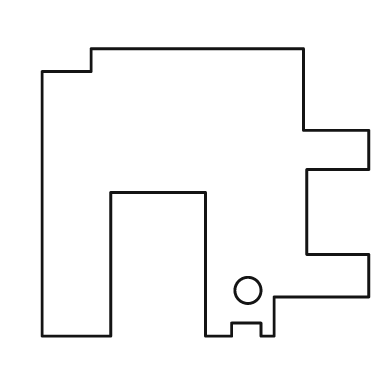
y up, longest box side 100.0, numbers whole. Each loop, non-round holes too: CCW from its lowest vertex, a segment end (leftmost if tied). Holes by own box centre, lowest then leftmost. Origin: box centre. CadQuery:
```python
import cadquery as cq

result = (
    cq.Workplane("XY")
    .moveTo(-50.0, -44.0)
    .lineTo(-29.0, -44.0)
    .lineTo(-29.0, 0.0)
    .lineTo(0.0, 0.0)
    .lineTo(0.0, -44.0)
    .lineTo(8.0, -44.0)
    .lineTo(8.0, -40.0)
    .lineTo(17.0, -40.0)
    .lineTo(17.0, -44.0)
    .lineTo(21.0, -44.0)
    .lineTo(21.0, -32.0)
    .lineTo(50.0, -32.0)
    .lineTo(50.0, -19.0)
    .lineTo(31.0, -19.0)
    .lineTo(31.0, 7.0)
    .lineTo(50.0, 7.0)
    .lineTo(50.0, 19.0)
    .lineTo(30.0, 19.0)
    .lineTo(30.0, 44.0)
    .lineTo(-35.0, 44.0)
    .lineTo(-35.0, 37.0)
    .lineTo(-50.0, 37.0)
    .close()
    .moveTo(13.0, -30.0)
    .circle(4.0)
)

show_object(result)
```